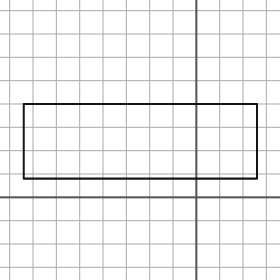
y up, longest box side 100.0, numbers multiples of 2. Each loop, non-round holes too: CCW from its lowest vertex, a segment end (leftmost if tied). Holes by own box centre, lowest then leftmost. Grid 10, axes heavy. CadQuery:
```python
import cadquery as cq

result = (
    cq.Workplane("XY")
    .moveTo(-74.0, 8.0)
    .lineTo(26.0, 8.0)
    .lineTo(26.0, 40.0)
    .lineTo(-74.0, 40.0)
    .close()
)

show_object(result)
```